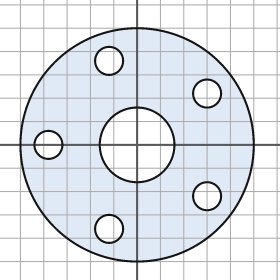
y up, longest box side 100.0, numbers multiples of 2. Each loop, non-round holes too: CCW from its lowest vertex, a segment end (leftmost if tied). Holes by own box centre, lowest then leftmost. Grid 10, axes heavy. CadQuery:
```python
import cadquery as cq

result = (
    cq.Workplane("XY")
    .moveTo(0.0, 0.0)
    .circle(50.0)
    .moveTo(-12.0, -36.0)
    .circle(6.0)
    .moveTo(30.0, -22.0)
    .circle(6.0)
    .moveTo(-38.0, 0.0)
    .circle(6.0)
    .moveTo(0.0, 0.0)
    .circle(16.0)
    .moveTo(30.0, 22.0)
    .circle(6.0)
    .moveTo(-12.0, 36.0)
    .circle(6.0)
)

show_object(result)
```